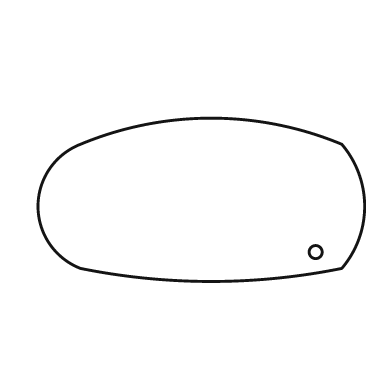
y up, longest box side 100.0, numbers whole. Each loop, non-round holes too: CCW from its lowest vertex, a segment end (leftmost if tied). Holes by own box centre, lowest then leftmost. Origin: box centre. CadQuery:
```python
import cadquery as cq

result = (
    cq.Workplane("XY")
    .moveTo(-37.0, -21.0)
    .threePointArc((3.0, -25.0), (43.0, -21.0))
    .threePointArc((50.0, -2.0), (43.0, 17.0))
    .threePointArc((3.0, 25.0), (-37.0, 17.0))
    .threePointArc((-50.0, -2.0), (-37.0, -21.0))
    .close()
    .moveTo(35.0, -16.0)
    .circle(2.0)
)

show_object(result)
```